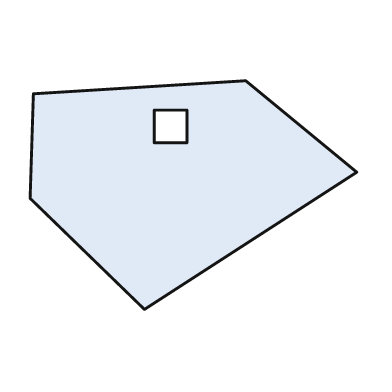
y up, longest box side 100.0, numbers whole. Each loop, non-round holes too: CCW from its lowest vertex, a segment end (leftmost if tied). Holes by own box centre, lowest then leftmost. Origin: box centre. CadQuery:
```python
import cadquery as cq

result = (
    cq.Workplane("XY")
    .moveTo(-15.0, -35.0)
    .lineTo(50.0, 7.0)
    .lineTo(16.0, 35.0)
    .lineTo(-49.0, 31.0)
    .lineTo(-50.0, -1.0)
    .close()
    .moveTo(-12.0, 16.0)
    .lineTo(-2.0, 16.0)
    .lineTo(-2.0, 26.0)
    .lineTo(-12.0, 26.0)
    .close()
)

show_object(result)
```